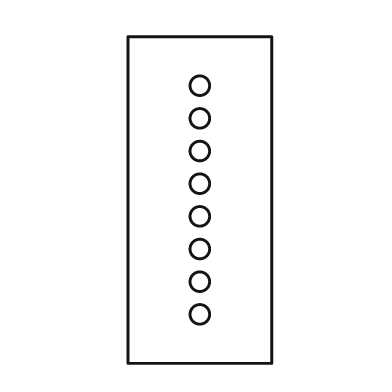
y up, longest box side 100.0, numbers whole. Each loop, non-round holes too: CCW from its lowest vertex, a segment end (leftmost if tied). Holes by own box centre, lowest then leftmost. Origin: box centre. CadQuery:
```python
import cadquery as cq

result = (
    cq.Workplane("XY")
    .moveTo(-22.0, -50.0)
    .lineTo(22.0, -50.0)
    .lineTo(22.0, 50.0)
    .lineTo(-22.0, 50.0)
    .close()
    .moveTo(0.0, -35.0)
    .circle(3.0)
    .moveTo(0.0, -25.0)
    .circle(3.0)
    .moveTo(0.0, -15.0)
    .circle(3.0)
    .moveTo(0.0, -5.0)
    .circle(3.0)
    .moveTo(0.0, 5.0)
    .circle(3.0)
    .moveTo(0.0, 15.0)
    .circle(3.0)
    .moveTo(0.0, 25.0)
    .circle(3.0)
    .moveTo(0.0, 35.0)
    .circle(3.0)
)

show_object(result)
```